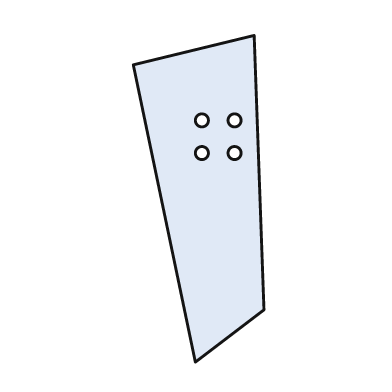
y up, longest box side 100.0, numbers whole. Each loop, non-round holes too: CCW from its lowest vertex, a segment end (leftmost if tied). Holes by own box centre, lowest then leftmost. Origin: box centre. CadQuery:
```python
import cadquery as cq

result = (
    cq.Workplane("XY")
    .moveTo(-1.0, -50.0)
    .lineTo(20.0, -34.0)
    .lineTo(17.0, 50.0)
    .lineTo(-20.0, 41.0)
    .close()
    .moveTo(1.0, 14.0)
    .circle(2.0)
    .moveTo(11.0, 14.0)
    .circle(2.0)
    .moveTo(1.0, 24.0)
    .circle(2.0)
    .moveTo(11.0, 24.0)
    .circle(2.0)
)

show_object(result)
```